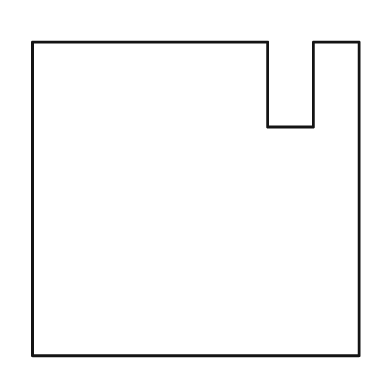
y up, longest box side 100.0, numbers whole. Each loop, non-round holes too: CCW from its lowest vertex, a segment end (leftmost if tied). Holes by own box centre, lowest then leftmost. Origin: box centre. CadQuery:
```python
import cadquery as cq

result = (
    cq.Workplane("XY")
    .moveTo(-50.0, -48.0)
    .lineTo(50.0, -48.0)
    .lineTo(50.0, 48.0)
    .lineTo(36.0, 48.0)
    .lineTo(36.0, 22.0)
    .lineTo(22.0, 22.0)
    .lineTo(22.0, 48.0)
    .lineTo(-50.0, 48.0)
    .close()
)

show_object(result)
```